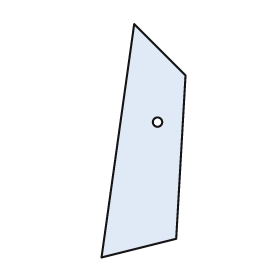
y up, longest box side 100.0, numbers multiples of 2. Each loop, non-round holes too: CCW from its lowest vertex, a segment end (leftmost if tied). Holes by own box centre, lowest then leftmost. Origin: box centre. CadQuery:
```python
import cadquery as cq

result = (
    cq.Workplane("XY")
    .moveTo(-18.0, -50.0)
    .lineTo(14.0, -42.0)
    .lineTo(18.0, 28.0)
    .lineTo(-4.0, 50.0)
    .close()
    .moveTo(6.0, 8.0)
    .circle(2.0)
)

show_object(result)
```